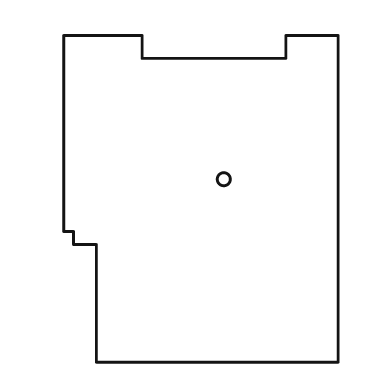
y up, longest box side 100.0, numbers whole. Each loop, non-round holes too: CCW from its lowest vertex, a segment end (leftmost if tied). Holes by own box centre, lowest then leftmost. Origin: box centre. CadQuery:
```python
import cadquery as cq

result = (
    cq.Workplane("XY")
    .moveTo(-32.0, -50.0)
    .lineTo(42.0, -50.0)
    .lineTo(42.0, 50.0)
    .lineTo(26.0, 50.0)
    .lineTo(26.0, 43.0)
    .lineTo(-18.0, 43.0)
    .lineTo(-18.0, 50.0)
    .lineTo(-42.0, 50.0)
    .lineTo(-42.0, -10.0)
    .lineTo(-39.0, -10.0)
    .lineTo(-39.0, -14.0)
    .lineTo(-32.0, -14.0)
    .close()
    .moveTo(7.0, 6.0)
    .circle(2.0)
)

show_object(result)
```